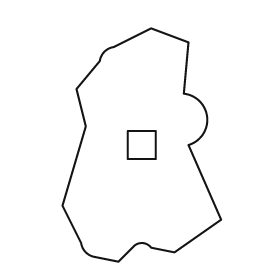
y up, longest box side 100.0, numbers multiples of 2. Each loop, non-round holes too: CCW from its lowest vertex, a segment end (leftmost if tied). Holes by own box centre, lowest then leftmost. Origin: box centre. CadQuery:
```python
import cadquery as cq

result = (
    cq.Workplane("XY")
    .moveTo(-10.0, -50.0)
    .lineTo(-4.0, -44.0)
    .threePointArc((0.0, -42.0), (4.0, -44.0))
    .lineTo(14.0, -46.0)
    .lineTo(34.0, -32.0)
    .lineTo(20.0, 0.0)
    .threePointArc((28.0, 12.0), (18.0, 22.0))
    .lineTo(20.0, 44.0)
    .lineTo(4.0, 50.0)
    .lineTo(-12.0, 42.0)
    .threePointArc((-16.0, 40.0), (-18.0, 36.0))
    .lineTo(-28.0, 24.0)
    .lineTo(-24.0, 8.0)
    .lineTo(-34.0, -26.0)
    .lineTo(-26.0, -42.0)
    .threePointArc((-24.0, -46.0), (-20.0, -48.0))
    .close()
    .moveTo(-6.0, -6.0)
    .lineTo(6.0, -6.0)
    .lineTo(6.0, 6.0)
    .lineTo(-6.0, 6.0)
    .close()
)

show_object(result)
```